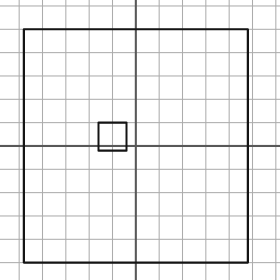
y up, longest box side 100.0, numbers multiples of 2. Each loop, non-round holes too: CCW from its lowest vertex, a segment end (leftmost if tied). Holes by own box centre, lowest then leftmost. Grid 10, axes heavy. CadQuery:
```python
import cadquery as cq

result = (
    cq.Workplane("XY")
    .moveTo(-48.0, -50.0)
    .lineTo(48.0, -50.0)
    .lineTo(48.0, 50.0)
    .lineTo(-48.0, 50.0)
    .close()
    .moveTo(-16.0, -2.0)
    .lineTo(-4.0, -2.0)
    .lineTo(-4.0, 10.0)
    .lineTo(-16.0, 10.0)
    .close()
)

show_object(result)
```